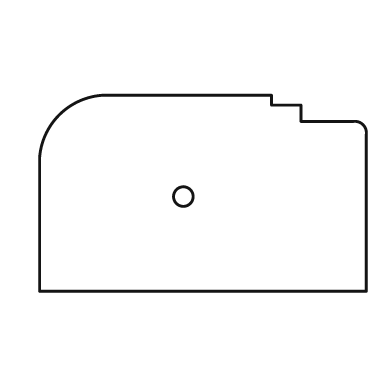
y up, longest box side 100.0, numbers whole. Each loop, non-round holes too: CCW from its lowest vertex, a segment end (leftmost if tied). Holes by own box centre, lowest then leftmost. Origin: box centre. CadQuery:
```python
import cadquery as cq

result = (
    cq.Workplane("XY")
    .moveTo(-50.0, -30.0)
    .lineTo(50.0, -30.0)
    .lineTo(50.0, 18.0)
    .threePointArc((49.0, 21.0), (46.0, 22.0))
    .lineTo(30.0, 22.0)
    .lineTo(30.0, 27.0)
    .lineTo(21.0, 27.0)
    .lineTo(21.0, 30.0)
    .lineTo(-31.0, 30.0)
    .threePointArc((-44.0, 24.0), (-50.0, 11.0))
    .close()
    .moveTo(-6.0, -1.0)
    .circle(3.0)
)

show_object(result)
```